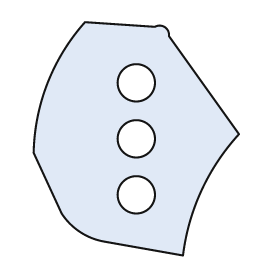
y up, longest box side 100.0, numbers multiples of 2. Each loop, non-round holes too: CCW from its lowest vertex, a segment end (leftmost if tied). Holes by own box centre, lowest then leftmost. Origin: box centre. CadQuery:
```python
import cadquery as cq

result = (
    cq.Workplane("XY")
    .moveTo(20.0, -50.0)
    .threePointArc((28.0, -22.0), (44.0, 2.0))
    .lineTo(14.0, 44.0)
    .threePointArc((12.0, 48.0), (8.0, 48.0))
    .lineTo(-22.0, 50.0)
    .threePointArc((-38.0, 24.0), (-44.0, -6.0))
    .lineTo(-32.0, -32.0)
    .threePointArc((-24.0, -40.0), (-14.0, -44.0))
    .close()
    .moveTo(0.0, -24.0)
    .circle(8.0)
    .moveTo(0.0, 0.0)
    .circle(8.0)
    .moveTo(0.0, 24.0)
    .circle(8.0)
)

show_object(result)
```